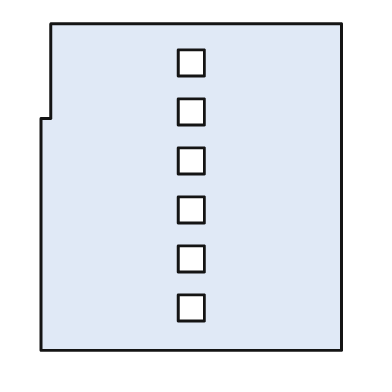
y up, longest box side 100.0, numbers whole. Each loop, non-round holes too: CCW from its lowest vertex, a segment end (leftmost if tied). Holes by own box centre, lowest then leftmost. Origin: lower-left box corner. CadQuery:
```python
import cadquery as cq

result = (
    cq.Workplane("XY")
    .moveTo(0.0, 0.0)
    .lineTo(92.0, 0.0)
    .lineTo(92.0, 100.0)
    .lineTo(3.0, 100.0)
    .lineTo(3.0, 71.0)
    .lineTo(0.0, 71.0)
    .close()
    .moveTo(42.0, 9.0)
    .lineTo(50.0, 9.0)
    .lineTo(50.0, 17.0)
    .lineTo(42.0, 17.0)
    .close()
    .moveTo(42.0, 24.0)
    .lineTo(50.0, 24.0)
    .lineTo(50.0, 32.0)
    .lineTo(42.0, 32.0)
    .close()
    .moveTo(42.0, 39.0)
    .lineTo(50.0, 39.0)
    .lineTo(50.0, 47.0)
    .lineTo(42.0, 47.0)
    .close()
    .moveTo(42.0, 54.0)
    .lineTo(50.0, 54.0)
    .lineTo(50.0, 62.0)
    .lineTo(42.0, 62.0)
    .close()
    .moveTo(42.0, 69.0)
    .lineTo(50.0, 69.0)
    .lineTo(50.0, 77.0)
    .lineTo(42.0, 77.0)
    .close()
    .moveTo(42.0, 84.0)
    .lineTo(50.0, 84.0)
    .lineTo(50.0, 92.0)
    .lineTo(42.0, 92.0)
    .close()
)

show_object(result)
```